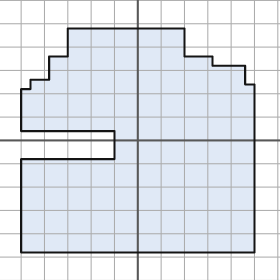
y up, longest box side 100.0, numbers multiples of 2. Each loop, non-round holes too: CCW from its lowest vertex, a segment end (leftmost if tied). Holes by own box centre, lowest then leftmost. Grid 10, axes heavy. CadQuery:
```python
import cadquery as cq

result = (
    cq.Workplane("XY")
    .moveTo(-50.0, -48.0)
    .lineTo(50.0, -48.0)
    .lineTo(50.0, 24.0)
    .lineTo(46.0, 24.0)
    .lineTo(46.0, 32.0)
    .lineTo(32.0, 32.0)
    .lineTo(32.0, 36.0)
    .lineTo(20.0, 36.0)
    .lineTo(20.0, 48.0)
    .lineTo(-30.0, 48.0)
    .lineTo(-30.0, 36.0)
    .lineTo(-38.0, 36.0)
    .lineTo(-38.0, 26.0)
    .lineTo(-46.0, 26.0)
    .lineTo(-46.0, 22.0)
    .lineTo(-50.0, 22.0)
    .lineTo(-50.0, 4.0)
    .lineTo(-10.0, 4.0)
    .lineTo(-10.0, -8.0)
    .lineTo(-50.0, -8.0)
    .close()
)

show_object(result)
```